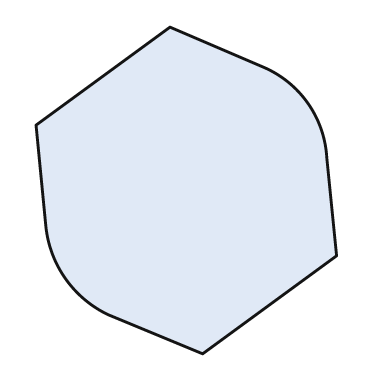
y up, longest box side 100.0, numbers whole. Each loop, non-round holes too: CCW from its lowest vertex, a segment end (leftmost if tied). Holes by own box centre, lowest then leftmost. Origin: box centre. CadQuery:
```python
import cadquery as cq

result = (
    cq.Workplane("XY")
    .moveTo(5.0, -50.0)
    .lineTo(46.0, -20.0)
    .lineTo(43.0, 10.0)
    .threePointArc((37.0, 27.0), (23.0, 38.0))
    .lineTo(-5.0, 50.0)
    .lineTo(-46.0, 20.0)
    .lineTo(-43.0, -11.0)
    .threePointArc((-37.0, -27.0), (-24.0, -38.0))
    .close()
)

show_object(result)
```